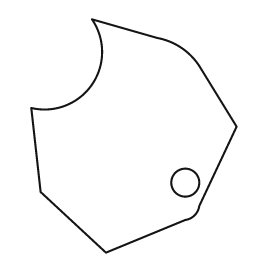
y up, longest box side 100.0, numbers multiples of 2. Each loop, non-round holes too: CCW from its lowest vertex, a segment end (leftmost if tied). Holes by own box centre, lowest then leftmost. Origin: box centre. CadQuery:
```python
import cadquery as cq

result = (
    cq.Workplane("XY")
    .moveTo(-12.0, -50.0)
    .lineTo(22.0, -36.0)
    .threePointArc((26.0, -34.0), (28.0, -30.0))
    .lineTo(44.0, 4.0)
    .lineTo(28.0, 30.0)
    .threePointArc((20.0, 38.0), (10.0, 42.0))
    .lineTo(-18.0, 50.0)
    .threePointArc((-18.0, 22.0), (-44.0, 12.0))
    .lineTo(-40.0, -24.0)
    .close()
    .moveTo(22.0, -20.0)
    .circle(6.0)
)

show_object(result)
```